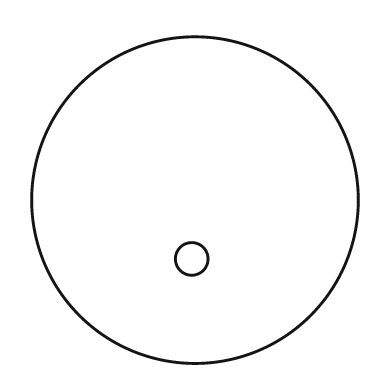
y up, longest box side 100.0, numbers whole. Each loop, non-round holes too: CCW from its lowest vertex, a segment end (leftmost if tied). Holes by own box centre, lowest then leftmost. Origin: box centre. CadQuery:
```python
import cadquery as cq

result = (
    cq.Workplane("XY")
    .moveTo(0.0, 0.0)
    .circle(50.0)
    .moveTo(-1.0, -18.0)
    .circle(5.0)
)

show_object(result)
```